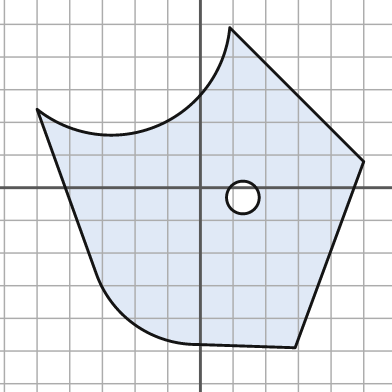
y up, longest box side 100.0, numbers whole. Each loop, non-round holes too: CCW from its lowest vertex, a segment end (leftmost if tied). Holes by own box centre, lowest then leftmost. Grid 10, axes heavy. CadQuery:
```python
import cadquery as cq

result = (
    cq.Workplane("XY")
    .moveTo(29.0, -49.0)
    .lineTo(50.0, 8.0)
    .lineTo(9.0, 49.0)
    .threePointArc((-13.0, 19.0), (-50.0, 24.0))
    .lineTo(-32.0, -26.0)
    .threePointArc((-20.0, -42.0), (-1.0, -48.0))
    .close()
    .moveTo(13.0, -3.0)
    .circle(5.0)
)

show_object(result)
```